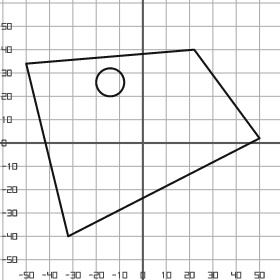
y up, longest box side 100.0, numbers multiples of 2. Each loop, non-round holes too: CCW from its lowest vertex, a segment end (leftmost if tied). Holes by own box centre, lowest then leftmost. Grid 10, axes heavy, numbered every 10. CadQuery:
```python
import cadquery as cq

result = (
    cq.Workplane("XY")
    .moveTo(-32.0, -40.0)
    .lineTo(50.0, 2.0)
    .lineTo(22.0, 40.0)
    .lineTo(-50.0, 34.0)
    .close()
    .moveTo(-14.0, 26.0)
    .circle(6.0)
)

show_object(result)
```